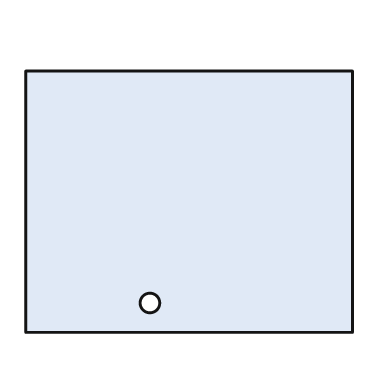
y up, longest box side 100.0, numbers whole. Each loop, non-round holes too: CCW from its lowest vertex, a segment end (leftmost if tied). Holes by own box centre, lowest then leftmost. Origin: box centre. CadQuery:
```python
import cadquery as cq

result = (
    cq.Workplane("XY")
    .moveTo(-50.0, -40.0)
    .lineTo(50.0, -40.0)
    .lineTo(50.0, 40.0)
    .lineTo(-50.0, 40.0)
    .close()
    .moveTo(-12.0, -31.0)
    .circle(3.0)
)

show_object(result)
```